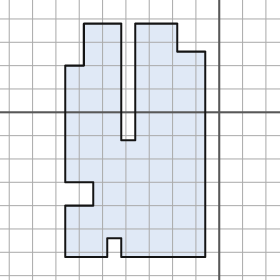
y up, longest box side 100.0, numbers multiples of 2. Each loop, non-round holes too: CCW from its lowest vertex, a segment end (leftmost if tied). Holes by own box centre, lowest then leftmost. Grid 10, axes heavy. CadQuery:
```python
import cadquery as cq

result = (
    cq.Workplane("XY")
    .moveTo(-66.0, -62.0)
    .lineTo(-48.0, -62.0)
    .lineTo(-48.0, -54.0)
    .lineTo(-42.0, -54.0)
    .lineTo(-42.0, -62.0)
    .lineTo(-6.0, -62.0)
    .lineTo(-6.0, 26.0)
    .lineTo(-18.0, 26.0)
    .lineTo(-18.0, 38.0)
    .lineTo(-36.0, 38.0)
    .lineTo(-36.0, -12.0)
    .lineTo(-42.0, -12.0)
    .lineTo(-42.0, 38.0)
    .lineTo(-58.0, 38.0)
    .lineTo(-58.0, 20.0)
    .lineTo(-66.0, 20.0)
    .lineTo(-66.0, -30.0)
    .lineTo(-54.0, -30.0)
    .lineTo(-54.0, -40.0)
    .lineTo(-66.0, -40.0)
    .close()
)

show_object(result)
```